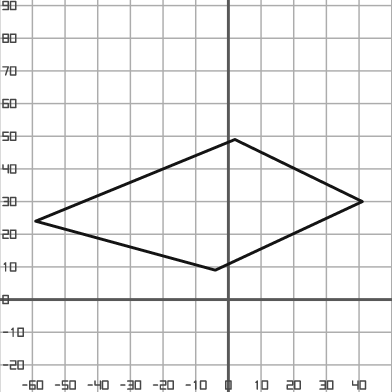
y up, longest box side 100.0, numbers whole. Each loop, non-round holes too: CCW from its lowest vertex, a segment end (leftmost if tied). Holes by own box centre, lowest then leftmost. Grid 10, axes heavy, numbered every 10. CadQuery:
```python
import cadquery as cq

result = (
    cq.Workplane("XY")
    .moveTo(-4.0, 9.0)
    .lineTo(41.0, 30.0)
    .lineTo(2.0, 49.0)
    .lineTo(-59.0, 24.0)
    .close()
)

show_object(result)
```